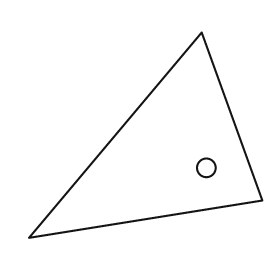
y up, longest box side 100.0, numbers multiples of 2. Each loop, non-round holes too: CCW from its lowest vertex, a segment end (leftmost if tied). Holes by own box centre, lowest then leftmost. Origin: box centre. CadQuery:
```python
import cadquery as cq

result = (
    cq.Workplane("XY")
    .moveTo(-50.0, -44.0)
    .lineTo(50.0, -28.0)
    .lineTo(24.0, 44.0)
    .close()
    .moveTo(26.0, -14.0)
    .circle(4.0)
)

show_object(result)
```